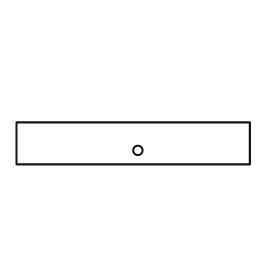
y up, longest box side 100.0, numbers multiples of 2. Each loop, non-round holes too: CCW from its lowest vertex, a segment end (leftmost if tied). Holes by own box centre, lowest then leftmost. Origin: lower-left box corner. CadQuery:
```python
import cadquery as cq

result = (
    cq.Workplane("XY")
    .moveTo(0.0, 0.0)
    .lineTo(100.0, 0.0)
    .lineTo(100.0, 18.0)
    .lineTo(0.0, 18.0)
    .close()
    .moveTo(52.0, 6.0)
    .circle(2.0)
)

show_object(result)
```